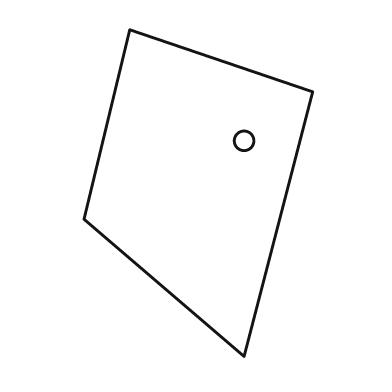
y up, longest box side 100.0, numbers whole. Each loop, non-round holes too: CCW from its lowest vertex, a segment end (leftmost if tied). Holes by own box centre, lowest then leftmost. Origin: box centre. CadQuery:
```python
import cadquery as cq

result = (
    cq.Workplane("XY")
    .moveTo(14.0, -50.0)
    .lineTo(35.0, 31.0)
    .lineTo(-21.0, 50.0)
    .lineTo(-35.0, -8.0)
    .close()
    .moveTo(14.0, 16.0)
    .circle(3.0)
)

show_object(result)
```